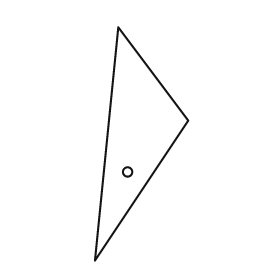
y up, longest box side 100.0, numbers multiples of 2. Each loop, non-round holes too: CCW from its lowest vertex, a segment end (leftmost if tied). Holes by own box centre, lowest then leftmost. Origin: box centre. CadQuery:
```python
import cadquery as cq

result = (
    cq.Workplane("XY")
    .moveTo(-20.0, -50.0)
    .lineTo(20.0, 10.0)
    .lineTo(-10.0, 50.0)
    .close()
    .moveTo(-6.0, -12.0)
    .circle(2.0)
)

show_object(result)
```